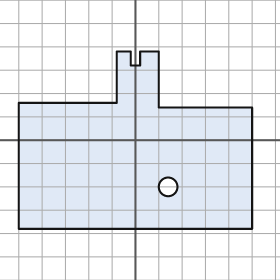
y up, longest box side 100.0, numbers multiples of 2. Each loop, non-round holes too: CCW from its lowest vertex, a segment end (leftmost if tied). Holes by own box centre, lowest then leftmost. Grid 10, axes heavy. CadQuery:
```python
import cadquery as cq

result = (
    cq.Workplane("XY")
    .moveTo(-50.0, -38.0)
    .lineTo(50.0, -38.0)
    .lineTo(50.0, 14.0)
    .lineTo(10.0, 14.0)
    .lineTo(10.0, 38.0)
    .lineTo(2.0, 38.0)
    .lineTo(2.0, 32.0)
    .lineTo(-2.0, 32.0)
    .lineTo(-2.0, 38.0)
    .lineTo(-8.0, 38.0)
    .lineTo(-8.0, 16.0)
    .lineTo(-50.0, 16.0)
    .close()
    .moveTo(14.0, -20.0)
    .circle(4.0)
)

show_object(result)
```